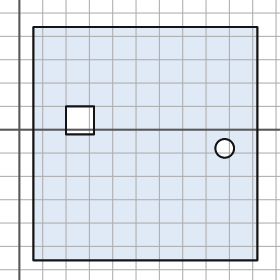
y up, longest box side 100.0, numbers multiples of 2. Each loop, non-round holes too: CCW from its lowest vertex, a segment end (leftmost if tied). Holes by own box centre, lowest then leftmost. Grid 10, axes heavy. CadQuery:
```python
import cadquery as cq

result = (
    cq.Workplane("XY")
    .moveTo(6.0, -56.0)
    .lineTo(102.0, -56.0)
    .lineTo(102.0, 44.0)
    .lineTo(6.0, 44.0)
    .close()
    .moveTo(88.0, -8.0)
    .circle(4.0)
    .moveTo(20.0, -2.0)
    .lineTo(32.0, -2.0)
    .lineTo(32.0, 10.0)
    .lineTo(20.0, 10.0)
    .close()
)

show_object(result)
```